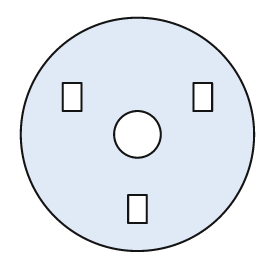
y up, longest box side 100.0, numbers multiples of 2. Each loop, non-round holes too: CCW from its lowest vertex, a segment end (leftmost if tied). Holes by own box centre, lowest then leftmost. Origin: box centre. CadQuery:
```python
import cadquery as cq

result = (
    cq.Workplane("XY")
    .moveTo(0.0, 0.0)
    .circle(50.0)
    .moveTo(-4.0, -38.0)
    .lineTo(4.0, -38.0)
    .lineTo(4.0, -26.0)
    .lineTo(-4.0, -26.0)
    .close()
    .moveTo(0.0, 0.0)
    .circle(10.0)
    .moveTo(-32.0, 10.0)
    .lineTo(-24.0, 10.0)
    .lineTo(-24.0, 22.0)
    .lineTo(-32.0, 22.0)
    .close()
    .moveTo(24.0, 10.0)
    .lineTo(32.0, 10.0)
    .lineTo(32.0, 22.0)
    .lineTo(24.0, 22.0)
    .close()
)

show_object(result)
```